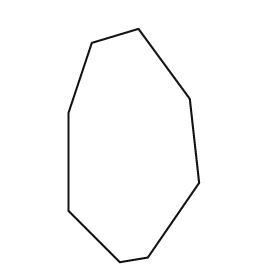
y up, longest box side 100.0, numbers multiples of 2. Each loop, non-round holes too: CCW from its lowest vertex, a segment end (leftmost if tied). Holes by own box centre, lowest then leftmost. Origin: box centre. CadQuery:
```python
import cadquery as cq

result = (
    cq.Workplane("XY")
    .moveTo(-6.0, -50.0)
    .lineTo(6.0, -48.0)
    .lineTo(28.0, -16.0)
    .lineTo(24.0, 20.0)
    .lineTo(2.0, 50.0)
    .lineTo(-18.0, 44.0)
    .lineTo(-28.0, 14.0)
    .lineTo(-28.0, -28.0)
    .close()
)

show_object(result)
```